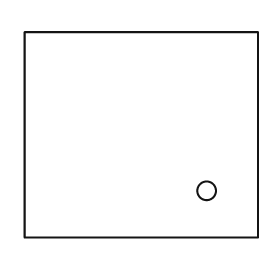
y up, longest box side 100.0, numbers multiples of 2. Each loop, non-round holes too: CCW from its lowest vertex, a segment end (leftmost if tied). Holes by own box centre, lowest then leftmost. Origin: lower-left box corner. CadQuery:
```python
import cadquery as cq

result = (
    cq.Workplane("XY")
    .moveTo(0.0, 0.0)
    .lineTo(100.0, 0.0)
    .lineTo(100.0, 88.0)
    .lineTo(0.0, 88.0)
    .close()
    .moveTo(78.0, 20.0)
    .circle(4.0)
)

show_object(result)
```